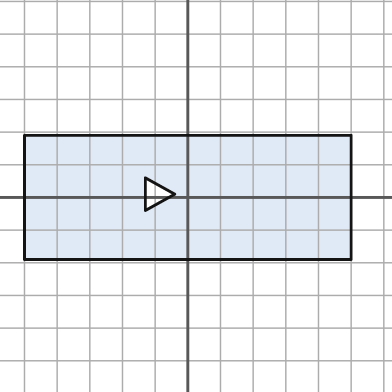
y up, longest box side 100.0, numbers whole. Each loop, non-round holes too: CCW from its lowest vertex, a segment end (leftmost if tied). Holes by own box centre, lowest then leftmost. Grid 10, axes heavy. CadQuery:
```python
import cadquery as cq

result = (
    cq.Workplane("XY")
    .moveTo(-50.0, -19.0)
    .lineTo(50.0, -19.0)
    .lineTo(50.0, 19.0)
    .lineTo(-50.0, 19.0)
    .close()
    .moveTo(-13.0, -4.0)
    .lineTo(-4.0, 1.0)
    .lineTo(-13.0, 6.0)
    .close()
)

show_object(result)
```